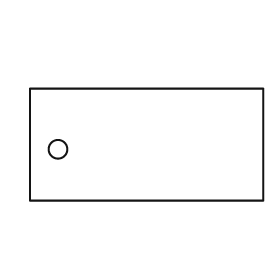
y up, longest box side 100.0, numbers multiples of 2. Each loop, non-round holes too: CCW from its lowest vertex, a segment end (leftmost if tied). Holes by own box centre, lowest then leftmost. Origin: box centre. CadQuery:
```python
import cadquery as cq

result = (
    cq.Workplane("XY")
    .moveTo(-50.0, -24.0)
    .lineTo(50.0, -24.0)
    .lineTo(50.0, 24.0)
    .lineTo(-50.0, 24.0)
    .close()
    .moveTo(-38.0, -2.0)
    .circle(4.0)
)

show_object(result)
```